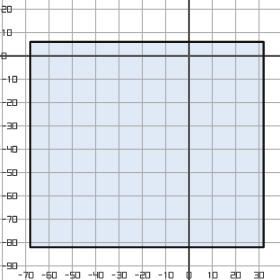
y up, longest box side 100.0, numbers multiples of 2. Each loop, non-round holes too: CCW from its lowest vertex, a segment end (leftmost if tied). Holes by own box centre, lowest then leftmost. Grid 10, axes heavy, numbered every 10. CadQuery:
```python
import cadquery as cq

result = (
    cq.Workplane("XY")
    .moveTo(-68.0, -82.0)
    .lineTo(32.0, -82.0)
    .lineTo(32.0, 6.0)
    .lineTo(-68.0, 6.0)
    .close()
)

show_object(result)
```